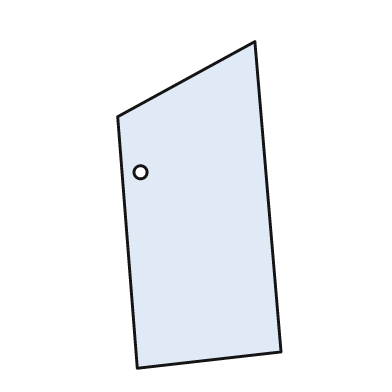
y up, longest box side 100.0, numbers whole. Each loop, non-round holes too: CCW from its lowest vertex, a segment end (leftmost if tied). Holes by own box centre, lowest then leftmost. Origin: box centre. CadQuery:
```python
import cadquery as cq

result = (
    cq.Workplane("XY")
    .moveTo(-19.0, -50.0)
    .lineTo(25.0, -45.0)
    .lineTo(17.0, 50.0)
    .lineTo(-25.0, 27.0)
    .close()
    .moveTo(-18.0, 10.0)
    .circle(2.0)
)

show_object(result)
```